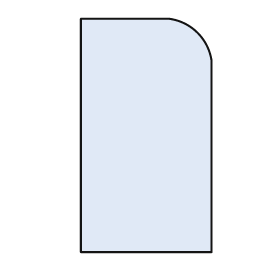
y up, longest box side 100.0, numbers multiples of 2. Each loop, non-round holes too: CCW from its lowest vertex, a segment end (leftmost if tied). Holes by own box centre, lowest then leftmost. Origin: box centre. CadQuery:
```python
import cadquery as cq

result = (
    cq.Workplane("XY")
    .moveTo(-28.0, -50.0)
    .lineTo(28.0, -50.0)
    .lineTo(28.0, 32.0)
    .threePointArc((22.0, 44.0), (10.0, 50.0))
    .lineTo(-28.0, 50.0)
    .close()
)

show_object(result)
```